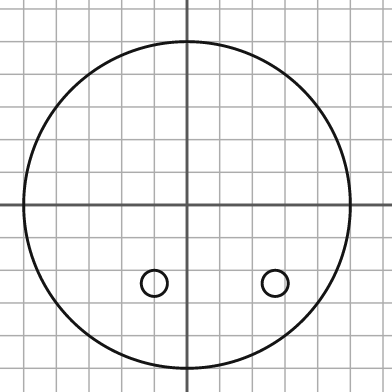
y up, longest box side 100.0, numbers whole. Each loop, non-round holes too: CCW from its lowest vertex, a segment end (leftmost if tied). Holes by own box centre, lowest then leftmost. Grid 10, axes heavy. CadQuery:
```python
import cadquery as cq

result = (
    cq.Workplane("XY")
    .moveTo(0.0, 0.0)
    .circle(50.0)
    .moveTo(-10.0, -24.0)
    .circle(4.0)
    .moveTo(27.0, -24.0)
    .circle(4.0)
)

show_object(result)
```